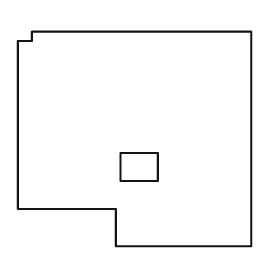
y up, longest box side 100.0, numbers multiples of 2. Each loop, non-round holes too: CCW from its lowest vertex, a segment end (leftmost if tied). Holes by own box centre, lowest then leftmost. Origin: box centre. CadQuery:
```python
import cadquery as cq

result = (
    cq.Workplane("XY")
    .moveTo(-8.0, -46.0)
    .lineTo(50.0, -46.0)
    .lineTo(50.0, 46.0)
    .lineTo(-44.0, 46.0)
    .lineTo(-44.0, 42.0)
    .lineTo(-50.0, 42.0)
    .lineTo(-50.0, -30.0)
    .lineTo(-8.0, -30.0)
    .close()
    .moveTo(-6.0, -18.0)
    .lineTo(10.0, -18.0)
    .lineTo(10.0, -6.0)
    .lineTo(-6.0, -6.0)
    .close()
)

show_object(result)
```